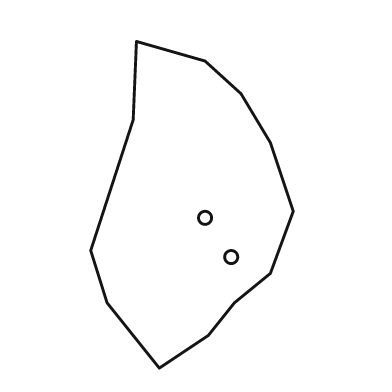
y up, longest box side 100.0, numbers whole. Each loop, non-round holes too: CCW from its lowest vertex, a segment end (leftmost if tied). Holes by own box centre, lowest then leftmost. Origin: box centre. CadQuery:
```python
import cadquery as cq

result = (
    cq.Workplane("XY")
    .moveTo(-10.0, -50.0)
    .lineTo(5.0, -40.0)
    .lineTo(13.0, -30.0)
    .lineTo(24.0, -21.0)
    .lineTo(31.0, -2.0)
    .lineTo(24.0, 19.0)
    .lineTo(15.0, 34.0)
    .lineTo(4.0, 44.0)
    .lineTo(-17.0, 50.0)
    .lineTo(-18.0, 26.0)
    .lineTo(-31.0, -14.0)
    .lineTo(-26.0, -30.0)
    .close()
    .moveTo(12.0, -16.0)
    .circle(2.0)
    .moveTo(4.0, -4.0)
    .circle(2.0)
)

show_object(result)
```